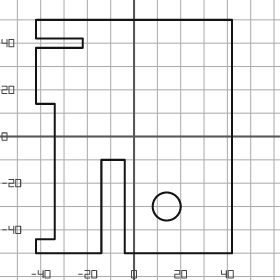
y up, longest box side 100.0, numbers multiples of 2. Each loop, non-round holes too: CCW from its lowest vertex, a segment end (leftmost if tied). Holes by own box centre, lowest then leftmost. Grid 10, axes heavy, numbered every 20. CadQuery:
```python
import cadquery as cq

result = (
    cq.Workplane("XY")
    .moveTo(-42.0, -50.0)
    .lineTo(-14.0, -50.0)
    .lineTo(-14.0, -10.0)
    .lineTo(-4.0, -10.0)
    .lineTo(-4.0, -50.0)
    .lineTo(42.0, -50.0)
    .lineTo(42.0, 50.0)
    .lineTo(-42.0, 50.0)
    .lineTo(-42.0, 42.0)
    .lineTo(-22.0, 42.0)
    .lineTo(-22.0, 38.0)
    .lineTo(-42.0, 38.0)
    .lineTo(-42.0, 14.0)
    .lineTo(-34.0, 14.0)
    .lineTo(-34.0, -44.0)
    .lineTo(-42.0, -44.0)
    .close()
    .moveTo(14.0, -30.0)
    .circle(6.0)
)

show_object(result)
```